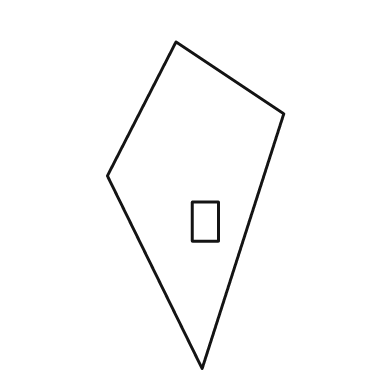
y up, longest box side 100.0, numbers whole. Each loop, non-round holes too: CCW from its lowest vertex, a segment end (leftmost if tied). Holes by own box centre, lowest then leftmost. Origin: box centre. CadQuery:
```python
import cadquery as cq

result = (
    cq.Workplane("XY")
    .moveTo(2.0, -50.0)
    .lineTo(27.0, 28.0)
    .lineTo(-6.0, 50.0)
    .lineTo(-27.0, 9.0)
    .close()
    .moveTo(-1.0, -11.0)
    .lineTo(7.0, -11.0)
    .lineTo(7.0, 1.0)
    .lineTo(-1.0, 1.0)
    .close()
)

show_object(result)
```